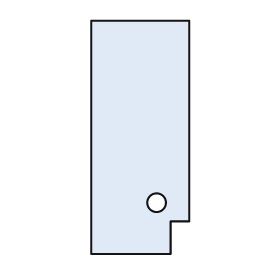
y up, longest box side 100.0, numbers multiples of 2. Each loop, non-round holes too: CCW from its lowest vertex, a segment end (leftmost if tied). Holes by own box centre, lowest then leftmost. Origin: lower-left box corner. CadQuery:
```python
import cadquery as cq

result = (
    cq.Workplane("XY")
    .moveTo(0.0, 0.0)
    .lineTo(34.0, 0.0)
    .lineTo(34.0, 14.0)
    .lineTo(42.0, 14.0)
    .lineTo(42.0, 100.0)
    .lineTo(0.0, 100.0)
    .close()
    .moveTo(28.0, 22.0)
    .circle(4.0)
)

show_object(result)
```